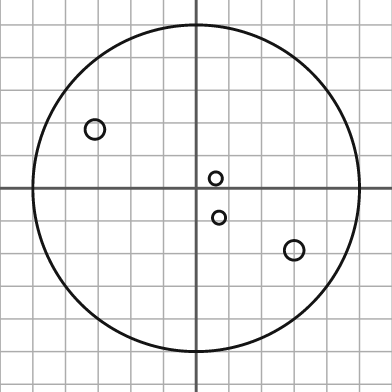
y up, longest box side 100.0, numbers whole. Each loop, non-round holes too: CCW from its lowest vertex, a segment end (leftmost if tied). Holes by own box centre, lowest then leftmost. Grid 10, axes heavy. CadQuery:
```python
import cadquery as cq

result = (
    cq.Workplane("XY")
    .moveTo(0.0, 0.0)
    .circle(50.0)
    .moveTo(30.0, -19.0)
    .circle(3.0)
    .moveTo(7.0, -9.0)
    .circle(2.0)
    .moveTo(6.0, 3.0)
    .circle(2.0)
    .moveTo(-31.0, 18.0)
    .circle(3.0)
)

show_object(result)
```